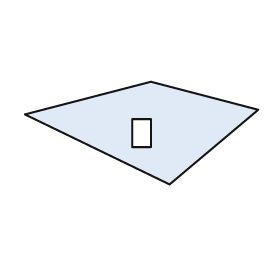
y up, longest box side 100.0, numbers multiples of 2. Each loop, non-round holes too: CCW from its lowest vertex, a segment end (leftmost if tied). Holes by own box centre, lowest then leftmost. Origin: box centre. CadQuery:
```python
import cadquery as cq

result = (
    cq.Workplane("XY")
    .moveTo(12.0, -22.0)
    .lineTo(50.0, 10.0)
    .lineTo(4.0, 22.0)
    .lineTo(-50.0, 8.0)
    .close()
    .moveTo(-4.0, -6.0)
    .lineTo(4.0, -6.0)
    .lineTo(4.0, 6.0)
    .lineTo(-4.0, 6.0)
    .close()
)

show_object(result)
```